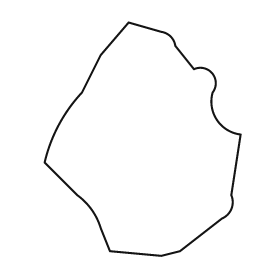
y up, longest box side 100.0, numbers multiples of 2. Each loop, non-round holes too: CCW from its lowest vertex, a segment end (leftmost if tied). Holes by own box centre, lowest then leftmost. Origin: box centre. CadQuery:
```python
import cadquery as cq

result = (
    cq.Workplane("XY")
    .moveTo(8.0, -50.0)
    .lineTo(16.0, -48.0)
    .lineTo(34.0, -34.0)
    .threePointArc((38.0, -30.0), (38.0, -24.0))
    .lineTo(42.0, 2.0)
    .threePointArc((32.0, 8.0), (30.0, 20.0))
    .threePointArc((30.0, 28.0), (22.0, 30.0))
    .lineTo(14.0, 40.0)
    .threePointArc((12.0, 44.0), (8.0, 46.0))
    .lineTo(-6.0, 50.0)
    .lineTo(-18.0, 36.0)
    .lineTo(-26.0, 20.0)
    .threePointArc((-36.0, 6.0), (-42.0, -10.0))
    .lineTo(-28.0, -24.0)
    .threePointArc((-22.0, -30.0), (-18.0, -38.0))
    .lineTo(-14.0, -48.0)
    .close()
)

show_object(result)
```